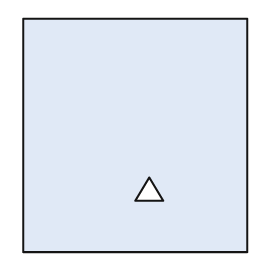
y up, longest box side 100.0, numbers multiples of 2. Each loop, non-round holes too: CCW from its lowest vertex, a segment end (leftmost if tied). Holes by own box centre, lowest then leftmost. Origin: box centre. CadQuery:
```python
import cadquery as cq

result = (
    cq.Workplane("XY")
    .moveTo(-48.0, -50.0)
    .lineTo(48.0, -50.0)
    .lineTo(48.0, 50.0)
    .lineTo(-48.0, 50.0)
    .close()
    .moveTo(0.0, -28.0)
    .lineTo(12.0, -28.0)
    .lineTo(6.0, -18.0)
    .close()
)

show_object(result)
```